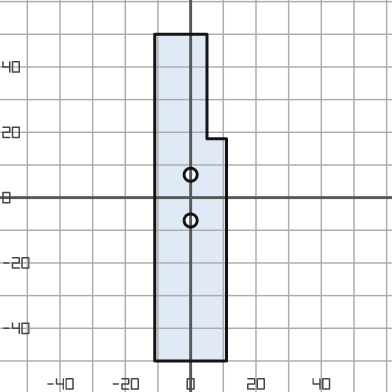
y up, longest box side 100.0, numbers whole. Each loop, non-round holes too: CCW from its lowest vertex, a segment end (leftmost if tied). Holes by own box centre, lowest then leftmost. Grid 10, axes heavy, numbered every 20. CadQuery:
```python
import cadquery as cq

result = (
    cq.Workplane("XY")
    .moveTo(-11.0, -50.0)
    .lineTo(11.0, -50.0)
    .lineTo(11.0, 18.0)
    .lineTo(5.0, 18.0)
    .lineTo(5.0, 50.0)
    .lineTo(-11.0, 50.0)
    .close()
    .moveTo(0.0, -7.0)
    .circle(2.0)
    .moveTo(0.0, 7.0)
    .circle(2.0)
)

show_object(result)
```